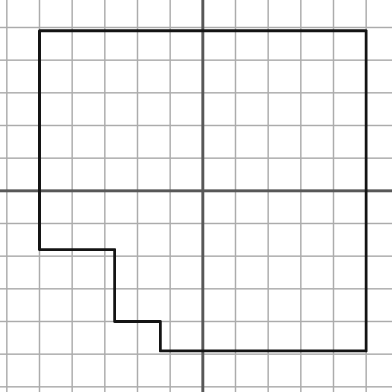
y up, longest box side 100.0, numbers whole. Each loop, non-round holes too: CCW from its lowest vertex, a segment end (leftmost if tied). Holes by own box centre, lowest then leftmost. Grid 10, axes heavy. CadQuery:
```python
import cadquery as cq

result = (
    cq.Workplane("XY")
    .moveTo(-13.0, -49.0)
    .lineTo(50.0, -49.0)
    .lineTo(50.0, 49.0)
    .lineTo(-50.0, 49.0)
    .lineTo(-50.0, -18.0)
    .lineTo(-27.0, -18.0)
    .lineTo(-27.0, -40.0)
    .lineTo(-13.0, -40.0)
    .close()
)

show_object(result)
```